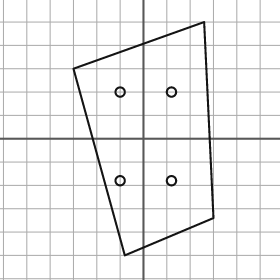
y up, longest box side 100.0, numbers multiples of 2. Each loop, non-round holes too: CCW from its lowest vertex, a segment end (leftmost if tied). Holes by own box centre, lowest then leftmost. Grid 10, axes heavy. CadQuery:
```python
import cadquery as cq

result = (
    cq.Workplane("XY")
    .moveTo(-8.0, -50.0)
    .lineTo(30.0, -34.0)
    .lineTo(26.0, 50.0)
    .lineTo(-30.0, 30.0)
    .close()
    .moveTo(-10.0, -18.0)
    .circle(2.0)
    .moveTo(12.0, -18.0)
    .circle(2.0)
    .moveTo(-10.0, 20.0)
    .circle(2.0)
    .moveTo(12.0, 20.0)
    .circle(2.0)
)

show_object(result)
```